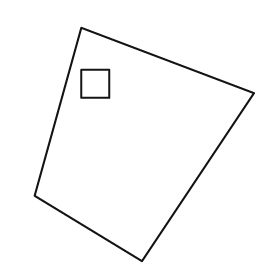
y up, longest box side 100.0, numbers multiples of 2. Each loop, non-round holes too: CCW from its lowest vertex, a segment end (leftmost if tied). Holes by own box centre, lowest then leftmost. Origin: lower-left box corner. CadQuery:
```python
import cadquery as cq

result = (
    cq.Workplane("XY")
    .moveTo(46.0, 0.0)
    .lineTo(94.0, 72.0)
    .lineTo(20.0, 100.0)
    .lineTo(0.0, 28.0)
    .close()
    .moveTo(20.0, 70.0)
    .lineTo(32.0, 70.0)
    .lineTo(32.0, 82.0)
    .lineTo(20.0, 82.0)
    .close()
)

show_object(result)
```